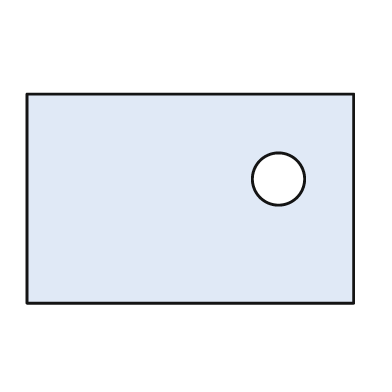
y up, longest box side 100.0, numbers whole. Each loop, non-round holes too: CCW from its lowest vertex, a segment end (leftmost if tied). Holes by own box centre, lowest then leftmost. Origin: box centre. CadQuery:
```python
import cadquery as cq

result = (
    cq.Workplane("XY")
    .moveTo(-50.0, -32.0)
    .lineTo(50.0, -32.0)
    .lineTo(50.0, 32.0)
    .lineTo(-50.0, 32.0)
    .close()
    .moveTo(27.0, 6.0)
    .circle(8.0)
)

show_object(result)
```